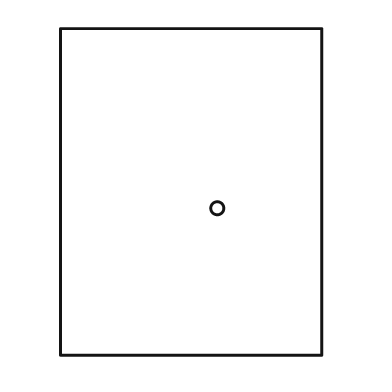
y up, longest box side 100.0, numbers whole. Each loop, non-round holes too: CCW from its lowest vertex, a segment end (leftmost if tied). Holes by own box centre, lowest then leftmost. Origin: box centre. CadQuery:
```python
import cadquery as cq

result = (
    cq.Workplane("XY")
    .moveTo(-40.0, -50.0)
    .lineTo(40.0, -50.0)
    .lineTo(40.0, 50.0)
    .lineTo(-40.0, 50.0)
    .close()
    .moveTo(8.0, -5.0)
    .circle(2.0)
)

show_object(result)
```